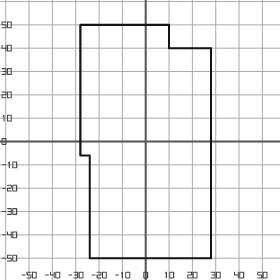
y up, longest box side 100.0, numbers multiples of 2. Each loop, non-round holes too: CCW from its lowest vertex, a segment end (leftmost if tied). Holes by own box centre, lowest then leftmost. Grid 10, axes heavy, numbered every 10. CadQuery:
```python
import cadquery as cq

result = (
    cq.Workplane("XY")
    .moveTo(-24.0, -50.0)
    .lineTo(28.0, -50.0)
    .lineTo(28.0, 40.0)
    .lineTo(10.0, 40.0)
    .lineTo(10.0, 50.0)
    .lineTo(-28.0, 50.0)
    .lineTo(-28.0, -6.0)
    .lineTo(-24.0, -6.0)
    .close()
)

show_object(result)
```